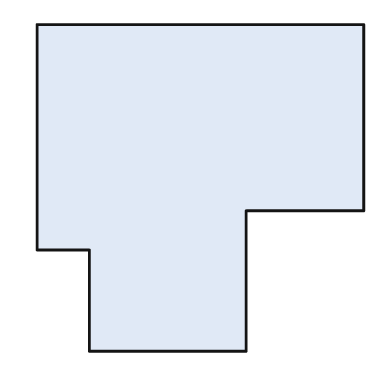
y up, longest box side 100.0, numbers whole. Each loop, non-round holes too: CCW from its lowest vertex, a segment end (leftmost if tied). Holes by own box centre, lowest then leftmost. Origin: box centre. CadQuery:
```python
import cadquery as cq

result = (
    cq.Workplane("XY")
    .moveTo(-34.0, -50.0)
    .lineTo(14.0, -50.0)
    .lineTo(14.0, -7.0)
    .lineTo(50.0, -7.0)
    .lineTo(50.0, 50.0)
    .lineTo(-50.0, 50.0)
    .lineTo(-50.0, -19.0)
    .lineTo(-34.0, -19.0)
    .close()
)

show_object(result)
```